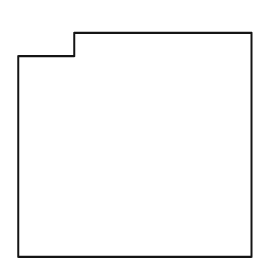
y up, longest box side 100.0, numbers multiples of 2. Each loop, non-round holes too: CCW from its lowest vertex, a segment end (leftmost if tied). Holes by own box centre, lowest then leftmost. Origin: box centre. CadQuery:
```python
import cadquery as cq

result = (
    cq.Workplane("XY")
    .moveTo(-50.0, -48.0)
    .lineTo(50.0, -48.0)
    .lineTo(50.0, 48.0)
    .lineTo(-26.0, 48.0)
    .lineTo(-26.0, 38.0)
    .lineTo(-50.0, 38.0)
    .close()
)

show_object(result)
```